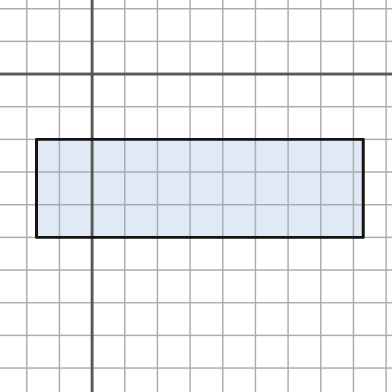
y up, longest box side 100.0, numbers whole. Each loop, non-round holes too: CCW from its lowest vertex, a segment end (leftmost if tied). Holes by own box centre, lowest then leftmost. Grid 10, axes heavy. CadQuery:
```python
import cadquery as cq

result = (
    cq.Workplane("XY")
    .moveTo(-17.0, -50.0)
    .lineTo(83.0, -50.0)
    .lineTo(83.0, -20.0)
    .lineTo(-17.0, -20.0)
    .close()
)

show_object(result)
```